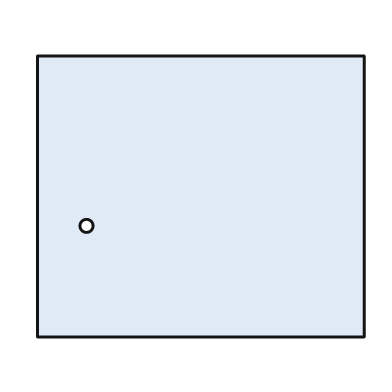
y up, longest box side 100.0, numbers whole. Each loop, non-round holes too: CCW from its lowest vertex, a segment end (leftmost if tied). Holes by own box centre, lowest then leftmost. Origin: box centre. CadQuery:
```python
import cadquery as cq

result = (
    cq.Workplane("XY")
    .moveTo(-50.0, -43.0)
    .lineTo(50.0, -43.0)
    .lineTo(50.0, 43.0)
    .lineTo(-50.0, 43.0)
    .close()
    .moveTo(-35.0, -9.0)
    .circle(2.0)
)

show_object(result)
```